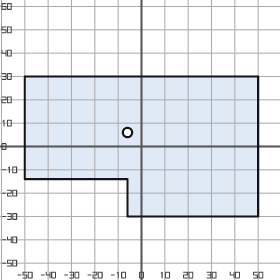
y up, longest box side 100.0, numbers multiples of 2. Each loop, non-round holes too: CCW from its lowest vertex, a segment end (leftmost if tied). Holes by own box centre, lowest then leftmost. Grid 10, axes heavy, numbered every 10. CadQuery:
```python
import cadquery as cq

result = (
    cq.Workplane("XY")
    .moveTo(-6.0, -30.0)
    .lineTo(50.0, -30.0)
    .lineTo(50.0, 30.0)
    .lineTo(-50.0, 30.0)
    .lineTo(-50.0, -14.0)
    .lineTo(-6.0, -14.0)
    .close()
    .moveTo(-6.0, 6.0)
    .circle(2.0)
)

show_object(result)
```